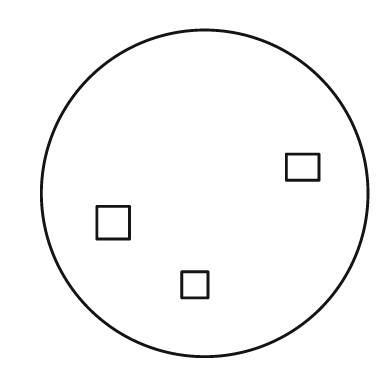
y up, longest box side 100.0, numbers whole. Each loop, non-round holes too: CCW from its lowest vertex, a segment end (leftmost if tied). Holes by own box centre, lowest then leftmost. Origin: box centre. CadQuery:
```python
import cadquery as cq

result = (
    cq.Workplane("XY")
    .moveTo(0.0, 0.0)
    .circle(50.0)
    .moveTo(-7.0, -32.0)
    .lineTo(1.0, -32.0)
    .lineTo(1.0, -24.0)
    .lineTo(-7.0, -24.0)
    .close()
    .moveTo(-33.0, -14.0)
    .lineTo(-23.0, -14.0)
    .lineTo(-23.0, -4.0)
    .lineTo(-33.0, -4.0)
    .close()
    .moveTo(25.0, 4.0)
    .lineTo(35.0, 4.0)
    .lineTo(35.0, 12.0)
    .lineTo(25.0, 12.0)
    .close()
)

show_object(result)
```